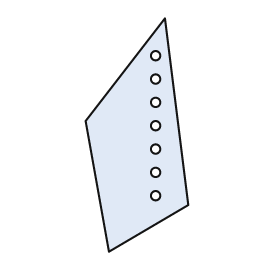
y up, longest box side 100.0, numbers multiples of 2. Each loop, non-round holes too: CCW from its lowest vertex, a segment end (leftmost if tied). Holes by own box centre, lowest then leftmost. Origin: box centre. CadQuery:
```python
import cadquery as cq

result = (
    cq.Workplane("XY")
    .moveTo(-12.0, -50.0)
    .lineTo(22.0, -30.0)
    .lineTo(12.0, 50.0)
    .lineTo(-22.0, 6.0)
    .close()
    .moveTo(8.0, -26.0)
    .circle(2.0)
    .moveTo(8.0, -16.0)
    .circle(2.0)
    .moveTo(8.0, -6.0)
    .circle(2.0)
    .moveTo(8.0, 4.0)
    .circle(2.0)
    .moveTo(8.0, 14.0)
    .circle(2.0)
    .moveTo(8.0, 24.0)
    .circle(2.0)
    .moveTo(8.0, 34.0)
    .circle(2.0)
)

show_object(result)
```